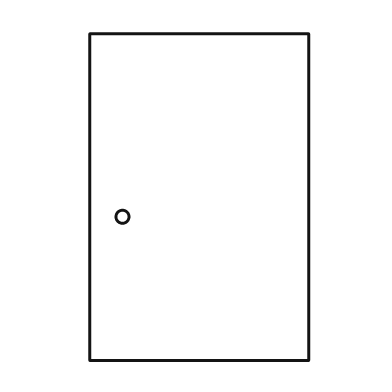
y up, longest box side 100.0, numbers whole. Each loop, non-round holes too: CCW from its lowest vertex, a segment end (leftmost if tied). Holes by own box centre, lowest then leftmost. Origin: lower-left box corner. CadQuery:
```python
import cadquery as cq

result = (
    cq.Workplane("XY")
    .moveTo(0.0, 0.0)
    .lineTo(67.0, 0.0)
    .lineTo(67.0, 100.0)
    .lineTo(0.0, 100.0)
    .close()
    .moveTo(10.0, 44.0)
    .circle(2.0)
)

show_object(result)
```